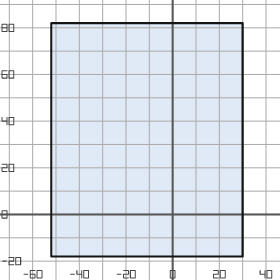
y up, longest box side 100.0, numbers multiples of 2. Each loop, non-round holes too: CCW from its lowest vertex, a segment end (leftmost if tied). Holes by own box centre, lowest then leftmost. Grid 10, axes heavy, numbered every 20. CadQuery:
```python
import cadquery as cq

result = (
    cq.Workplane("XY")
    .moveTo(-52.0, -18.0)
    .lineTo(30.0, -18.0)
    .lineTo(30.0, 82.0)
    .lineTo(-52.0, 82.0)
    .close()
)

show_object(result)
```